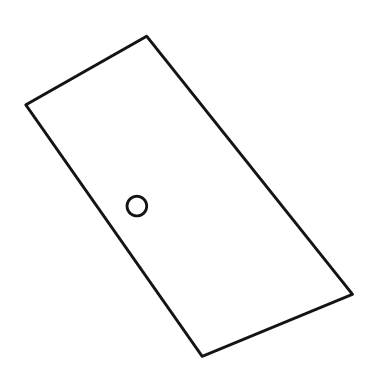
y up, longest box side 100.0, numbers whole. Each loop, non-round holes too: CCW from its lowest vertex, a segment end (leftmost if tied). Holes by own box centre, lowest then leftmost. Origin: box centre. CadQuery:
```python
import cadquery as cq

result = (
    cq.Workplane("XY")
    .moveTo(4.0, -49.0)
    .lineTo(50.0, -30.0)
    .lineTo(-13.0, 49.0)
    .lineTo(-50.0, 28.0)
    .close()
    .moveTo(-16.0, -3.0)
    .circle(3.0)
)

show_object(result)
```